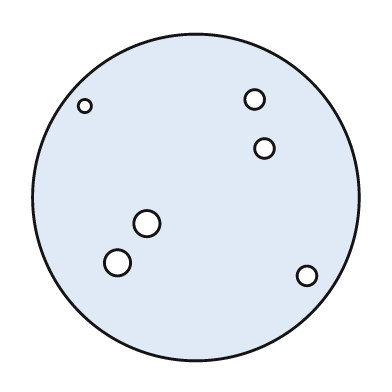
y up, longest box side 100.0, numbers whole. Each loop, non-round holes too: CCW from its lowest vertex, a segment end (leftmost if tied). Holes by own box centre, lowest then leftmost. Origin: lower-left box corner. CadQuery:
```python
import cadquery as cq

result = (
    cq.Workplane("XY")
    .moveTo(50.0, 50.0)
    .circle(50.0)
    .moveTo(84.0, 26.0)
    .circle(3.0)
    .moveTo(26.0, 30.0)
    .circle(4.0)
    .moveTo(35.0, 42.0)
    .circle(4.0)
    .moveTo(71.0, 65.0)
    .circle(3.0)
    .moveTo(16.0, 78.0)
    .circle(2.0)
    .moveTo(68.0, 80.0)
    .circle(3.0)
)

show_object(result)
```